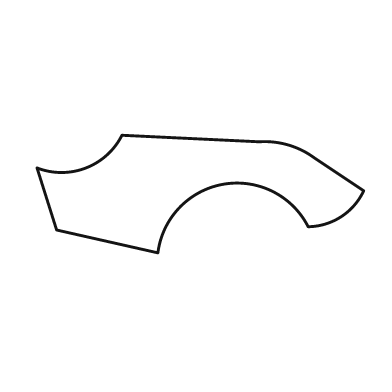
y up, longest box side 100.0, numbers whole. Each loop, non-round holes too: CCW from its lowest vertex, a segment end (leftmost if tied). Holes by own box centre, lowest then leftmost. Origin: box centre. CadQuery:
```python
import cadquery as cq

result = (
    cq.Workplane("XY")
    .moveTo(-13.0, -18.0)
    .threePointArc((7.0, 3.0), (33.0, -10.0))
    .threePointArc((43.0, -7.0), (50.0, 1.0))
    .lineTo(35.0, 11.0)
    .threePointArc((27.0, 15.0), (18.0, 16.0))
    .lineTo(-24.0, 18.0)
    .threePointArc((-35.0, 8.0), (-50.0, 8.0))
    .lineTo(-44.0, -11.0)
    .close()
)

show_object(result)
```